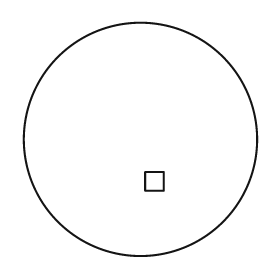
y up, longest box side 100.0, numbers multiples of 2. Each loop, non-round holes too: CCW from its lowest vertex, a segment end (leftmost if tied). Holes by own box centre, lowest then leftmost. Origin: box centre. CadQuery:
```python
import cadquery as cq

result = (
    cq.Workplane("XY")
    .moveTo(0.0, 0.0)
    .circle(50.0)
    .moveTo(2.0, -22.0)
    .lineTo(10.0, -22.0)
    .lineTo(10.0, -14.0)
    .lineTo(2.0, -14.0)
    .close()
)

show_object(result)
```